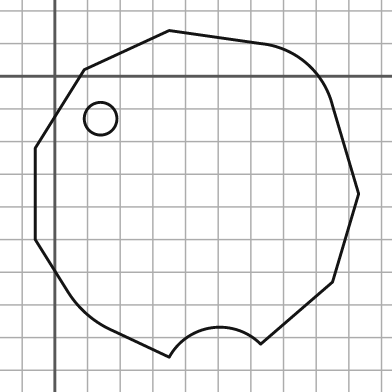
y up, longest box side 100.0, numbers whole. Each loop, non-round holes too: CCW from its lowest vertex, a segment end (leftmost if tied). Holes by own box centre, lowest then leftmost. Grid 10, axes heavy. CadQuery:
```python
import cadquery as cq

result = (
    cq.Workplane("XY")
    .moveTo(35.0, -86.0)
    .threePointArc((48.0, -77.0), (63.0, -82.0))
    .lineTo(85.0, -63.0)
    .lineTo(93.0, -36.0)
    .lineTo(85.0, -9.0)
    .threePointArc((77.0, 4.0), (63.0, 10.0))
    .lineTo(35.0, 14.0)
    .lineTo(9.0, 2.0)
    .lineTo(-6.0, -22.0)
    .lineTo(-6.0, -50.0)
    .lineTo(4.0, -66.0)
    .threePointArc((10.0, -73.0), (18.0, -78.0))
    .close()
    .moveTo(14.0, -13.0)
    .circle(5.0)
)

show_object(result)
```